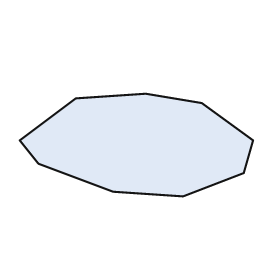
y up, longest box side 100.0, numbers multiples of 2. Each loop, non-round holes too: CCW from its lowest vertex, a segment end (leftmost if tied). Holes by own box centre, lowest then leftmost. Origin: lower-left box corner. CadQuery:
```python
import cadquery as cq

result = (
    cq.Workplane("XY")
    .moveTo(70.0, 0.0)
    .lineTo(96.0, 10.0)
    .lineTo(100.0, 24.0)
    .lineTo(78.0, 40.0)
    .lineTo(54.0, 44.0)
    .lineTo(24.0, 42.0)
    .lineTo(0.0, 24.0)
    .lineTo(8.0, 14.0)
    .lineTo(40.0, 2.0)
    .close()
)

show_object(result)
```